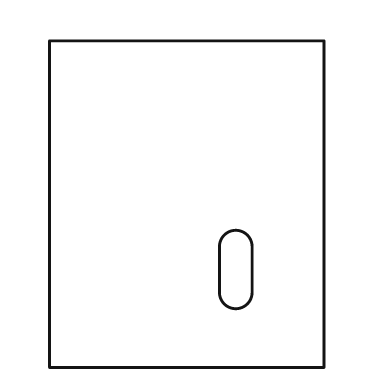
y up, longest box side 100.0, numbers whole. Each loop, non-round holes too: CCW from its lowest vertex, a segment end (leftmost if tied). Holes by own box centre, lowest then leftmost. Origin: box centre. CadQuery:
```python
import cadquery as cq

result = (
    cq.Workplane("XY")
    .moveTo(-42.0, -50.0)
    .lineTo(42.0, -50.0)
    .lineTo(42.0, 50.0)
    .lineTo(-42.0, 50.0)
    .close()
    .moveTo(10.0, -27.0)
    .threePointArc((15.0, -32.0), (20.0, -27.0))
    .lineTo(20.0, -13.0)
    .threePointArc((15.0, -8.0), (10.0, -13.0))
    .close()
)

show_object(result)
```